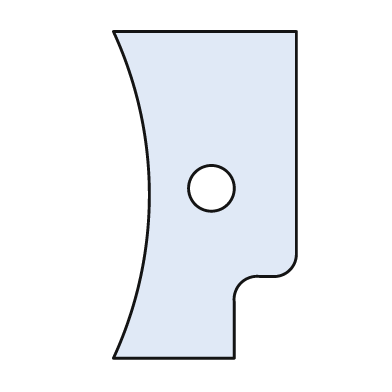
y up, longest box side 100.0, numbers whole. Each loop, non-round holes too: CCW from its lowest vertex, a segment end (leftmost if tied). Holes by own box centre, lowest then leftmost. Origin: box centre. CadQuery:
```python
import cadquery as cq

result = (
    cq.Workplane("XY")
    .moveTo(-28.0, -50.0)
    .lineTo(9.0, -50.0)
    .lineTo(9.0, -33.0)
    .threePointArc((11.0, -27.0), (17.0, -25.0))
    .lineTo(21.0, -25.0)
    .threePointArc((26.0, -23.0), (28.0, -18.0))
    .lineTo(28.0, 50.0)
    .lineTo(-28.0, 50.0)
    .threePointArc((-17.0, 0.0), (-28.0, -50.0))
    .close()
    .moveTo(2.0, 2.0)
    .circle(7.0)
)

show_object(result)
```